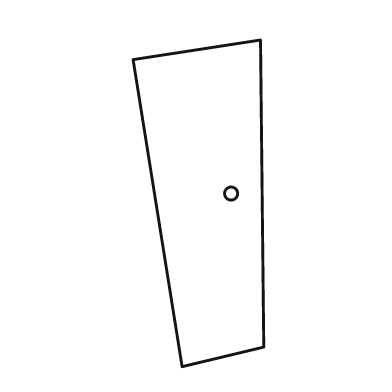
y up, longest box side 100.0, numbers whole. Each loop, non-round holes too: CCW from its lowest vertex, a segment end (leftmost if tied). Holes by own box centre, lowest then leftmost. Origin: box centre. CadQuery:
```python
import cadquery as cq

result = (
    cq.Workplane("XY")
    .moveTo(-5.0, -50.0)
    .lineTo(20.0, -44.0)
    .lineTo(19.0, 50.0)
    .lineTo(-20.0, 44.0)
    .close()
    .moveTo(10.0, 3.0)
    .circle(2.0)
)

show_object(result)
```